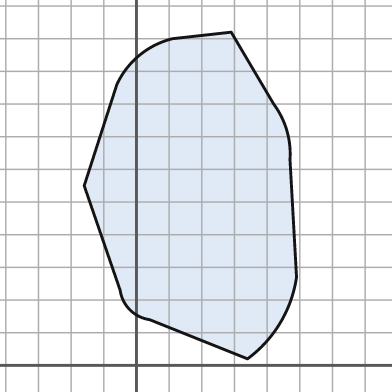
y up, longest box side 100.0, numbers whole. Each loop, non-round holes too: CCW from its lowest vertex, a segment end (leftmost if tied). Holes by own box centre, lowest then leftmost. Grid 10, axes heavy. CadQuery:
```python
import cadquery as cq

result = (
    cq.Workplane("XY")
    .moveTo(34.0, 2.0)
    .threePointArc((44.0, 13.0), (49.0, 27.0))
    .lineTo(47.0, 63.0)
    .threePointArc((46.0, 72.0), (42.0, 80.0))
    .lineTo(29.0, 102.0)
    .lineTo(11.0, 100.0)
    .threePointArc((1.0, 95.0), (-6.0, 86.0))
    .lineTo(-16.0, 55.0)
    .lineTo(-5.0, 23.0)
    .threePointArc((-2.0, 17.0), (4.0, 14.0))
    .close()
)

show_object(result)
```